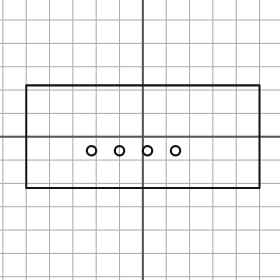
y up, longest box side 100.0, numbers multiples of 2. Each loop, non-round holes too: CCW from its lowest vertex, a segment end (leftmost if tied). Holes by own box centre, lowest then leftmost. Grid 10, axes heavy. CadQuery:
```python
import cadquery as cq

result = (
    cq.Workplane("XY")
    .moveTo(-50.0, -22.0)
    .lineTo(50.0, -22.0)
    .lineTo(50.0, 22.0)
    .lineTo(-50.0, 22.0)
    .close()
    .moveTo(-22.0, -6.0)
    .circle(2.0)
    .moveTo(-10.0, -6.0)
    .circle(2.0)
    .moveTo(2.0, -6.0)
    .circle(2.0)
    .moveTo(14.0, -6.0)
    .circle(2.0)
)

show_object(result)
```